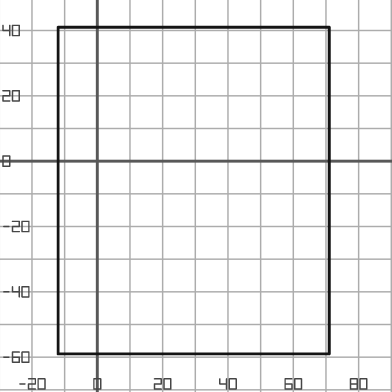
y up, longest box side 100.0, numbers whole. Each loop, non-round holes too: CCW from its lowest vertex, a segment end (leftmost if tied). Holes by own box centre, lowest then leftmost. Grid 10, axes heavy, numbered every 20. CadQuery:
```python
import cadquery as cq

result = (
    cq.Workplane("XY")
    .moveTo(-12.0, -59.0)
    .lineTo(71.0, -59.0)
    .lineTo(71.0, 41.0)
    .lineTo(-12.0, 41.0)
    .close()
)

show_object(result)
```